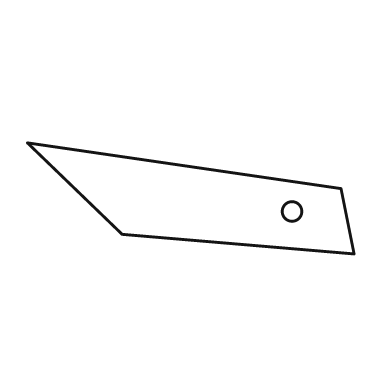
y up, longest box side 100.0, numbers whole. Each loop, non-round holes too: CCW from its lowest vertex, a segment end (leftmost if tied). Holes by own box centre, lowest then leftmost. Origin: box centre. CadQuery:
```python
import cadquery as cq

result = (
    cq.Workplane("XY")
    .moveTo(50.0, -17.0)
    .lineTo(46.0, 3.0)
    .lineTo(-50.0, 17.0)
    .lineTo(-21.0, -11.0)
    .close()
    .moveTo(31.0, -4.0)
    .circle(3.0)
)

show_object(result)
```